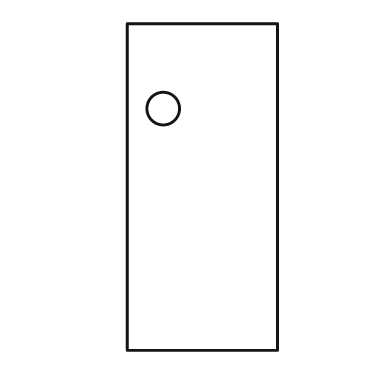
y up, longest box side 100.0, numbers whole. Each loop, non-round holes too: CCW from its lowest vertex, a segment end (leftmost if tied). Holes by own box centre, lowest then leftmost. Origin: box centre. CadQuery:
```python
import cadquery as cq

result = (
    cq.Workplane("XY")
    .moveTo(-23.0, -50.0)
    .lineTo(23.0, -50.0)
    .lineTo(23.0, 50.0)
    .lineTo(-23.0, 50.0)
    .close()
    .moveTo(-12.0, 24.0)
    .circle(5.0)
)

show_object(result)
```